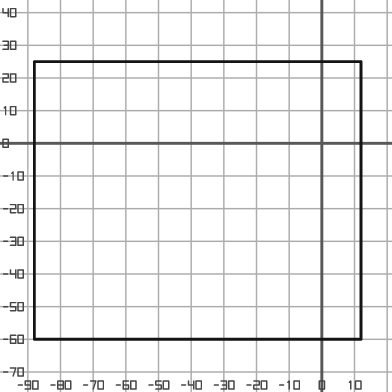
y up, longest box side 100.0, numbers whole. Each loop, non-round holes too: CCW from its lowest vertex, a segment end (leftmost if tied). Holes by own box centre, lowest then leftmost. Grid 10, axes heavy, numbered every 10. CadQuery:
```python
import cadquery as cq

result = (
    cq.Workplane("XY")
    .moveTo(-88.0, -60.0)
    .lineTo(12.0, -60.0)
    .lineTo(12.0, 25.0)
    .lineTo(-88.0, 25.0)
    .close()
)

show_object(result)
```